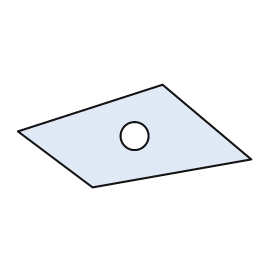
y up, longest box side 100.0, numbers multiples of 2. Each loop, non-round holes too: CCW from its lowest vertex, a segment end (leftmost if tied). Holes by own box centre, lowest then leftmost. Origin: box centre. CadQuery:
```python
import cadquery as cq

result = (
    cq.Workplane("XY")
    .moveTo(-18.0, -22.0)
    .lineTo(50.0, -10.0)
    .lineTo(12.0, 22.0)
    .lineTo(-50.0, 2.0)
    .close()
    .moveTo(0.0, 0.0)
    .circle(6.0)
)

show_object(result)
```